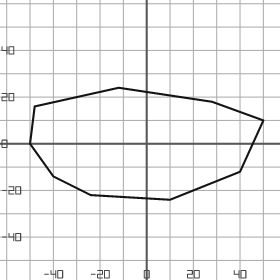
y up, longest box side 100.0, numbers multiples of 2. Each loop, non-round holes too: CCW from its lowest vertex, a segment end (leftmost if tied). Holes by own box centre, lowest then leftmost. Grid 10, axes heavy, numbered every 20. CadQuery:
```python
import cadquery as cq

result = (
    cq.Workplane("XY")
    .moveTo(10.0, -24.0)
    .lineTo(40.0, -12.0)
    .lineTo(50.0, 10.0)
    .lineTo(28.0, 18.0)
    .lineTo(-12.0, 24.0)
    .lineTo(-48.0, 16.0)
    .lineTo(-50.0, 0.0)
    .lineTo(-40.0, -14.0)
    .lineTo(-24.0, -22.0)
    .close()
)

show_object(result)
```